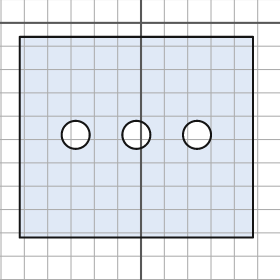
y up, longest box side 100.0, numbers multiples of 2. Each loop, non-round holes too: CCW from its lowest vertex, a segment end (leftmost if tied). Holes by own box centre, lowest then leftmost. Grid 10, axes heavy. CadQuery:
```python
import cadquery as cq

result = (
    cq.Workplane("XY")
    .moveTo(-52.0, -92.0)
    .lineTo(48.0, -92.0)
    .lineTo(48.0, -6.0)
    .lineTo(-52.0, -6.0)
    .close()
    .moveTo(-28.0, -48.0)
    .circle(6.0)
    .moveTo(-2.0, -48.0)
    .circle(6.0)
    .moveTo(24.0, -48.0)
    .circle(6.0)
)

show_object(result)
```